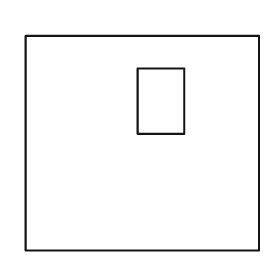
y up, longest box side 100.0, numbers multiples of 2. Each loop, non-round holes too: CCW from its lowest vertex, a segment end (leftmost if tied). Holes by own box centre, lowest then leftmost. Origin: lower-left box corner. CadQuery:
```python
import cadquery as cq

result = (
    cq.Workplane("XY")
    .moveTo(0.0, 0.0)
    .lineTo(100.0, 0.0)
    .lineTo(100.0, 92.0)
    .lineTo(0.0, 92.0)
    .close()
    .moveTo(48.0, 50.0)
    .lineTo(68.0, 50.0)
    .lineTo(68.0, 78.0)
    .lineTo(48.0, 78.0)
    .close()
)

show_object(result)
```